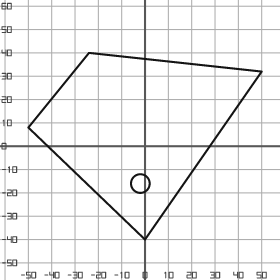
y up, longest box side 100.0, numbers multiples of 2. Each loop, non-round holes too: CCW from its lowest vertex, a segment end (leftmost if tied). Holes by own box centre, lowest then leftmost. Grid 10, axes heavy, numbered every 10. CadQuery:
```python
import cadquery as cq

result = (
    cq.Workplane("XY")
    .moveTo(0.0, -40.0)
    .lineTo(50.0, 32.0)
    .lineTo(-24.0, 40.0)
    .lineTo(-50.0, 8.0)
    .close()
    .moveTo(-2.0, -16.0)
    .circle(4.0)
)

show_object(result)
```